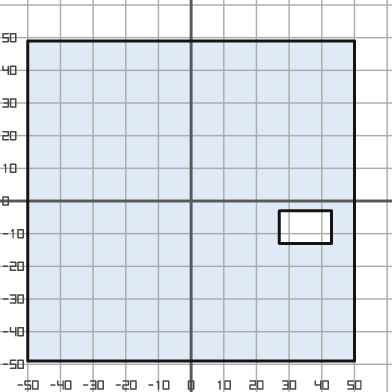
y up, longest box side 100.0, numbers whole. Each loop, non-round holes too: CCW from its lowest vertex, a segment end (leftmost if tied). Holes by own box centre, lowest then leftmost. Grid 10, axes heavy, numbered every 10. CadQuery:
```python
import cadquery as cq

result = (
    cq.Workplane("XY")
    .moveTo(-50.0, -49.0)
    .lineTo(50.0, -49.0)
    .lineTo(50.0, 49.0)
    .lineTo(-50.0, 49.0)
    .close()
    .moveTo(27.0, -13.0)
    .lineTo(43.0, -13.0)
    .lineTo(43.0, -3.0)
    .lineTo(27.0, -3.0)
    .close()
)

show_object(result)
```